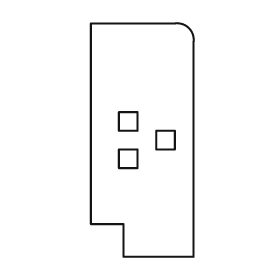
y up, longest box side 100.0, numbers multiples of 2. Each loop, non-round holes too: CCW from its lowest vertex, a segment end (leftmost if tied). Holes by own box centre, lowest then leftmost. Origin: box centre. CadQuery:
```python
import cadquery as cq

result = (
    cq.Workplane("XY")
    .moveTo(-8.0, -50.0)
    .lineTo(22.0, -50.0)
    .lineTo(22.0, 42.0)
    .threePointArc((20.0, 48.0), (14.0, 50.0))
    .lineTo(-22.0, 50.0)
    .lineTo(-22.0, -36.0)
    .lineTo(-8.0, -36.0)
    .close()
    .moveTo(-10.0, -12.0)
    .lineTo(-2.0, -12.0)
    .lineTo(-2.0, -4.0)
    .lineTo(-10.0, -4.0)
    .close()
    .moveTo(6.0, -4.0)
    .lineTo(14.0, -4.0)
    .lineTo(14.0, 4.0)
    .lineTo(6.0, 4.0)
    .close()
    .moveTo(-10.0, 4.0)
    .lineTo(-2.0, 4.0)
    .lineTo(-2.0, 12.0)
    .lineTo(-10.0, 12.0)
    .close()
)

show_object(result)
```